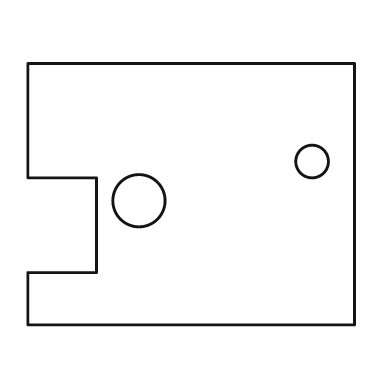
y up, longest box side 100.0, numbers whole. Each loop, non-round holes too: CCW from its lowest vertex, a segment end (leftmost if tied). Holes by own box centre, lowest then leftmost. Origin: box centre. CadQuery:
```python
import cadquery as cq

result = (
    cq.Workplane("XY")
    .moveTo(-50.0, -40.0)
    .lineTo(50.0, -40.0)
    .lineTo(50.0, 40.0)
    .lineTo(-50.0, 40.0)
    .lineTo(-50.0, 5.0)
    .lineTo(-29.0, 5.0)
    .lineTo(-29.0, -24.0)
    .lineTo(-50.0, -24.0)
    .close()
    .moveTo(-16.0, -2.0)
    .circle(8.0)
    .moveTo(37.0, 10.0)
    .circle(5.0)
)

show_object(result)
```